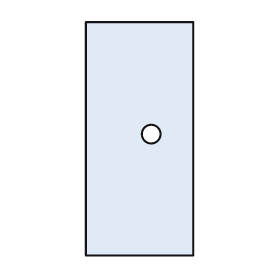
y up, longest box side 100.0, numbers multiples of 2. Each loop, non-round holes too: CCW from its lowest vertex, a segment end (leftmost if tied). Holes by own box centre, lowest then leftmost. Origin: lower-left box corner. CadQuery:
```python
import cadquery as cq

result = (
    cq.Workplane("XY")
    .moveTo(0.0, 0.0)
    .lineTo(46.0, 0.0)
    .lineTo(46.0, 100.0)
    .lineTo(0.0, 100.0)
    .close()
    .moveTo(28.0, 52.0)
    .circle(4.0)
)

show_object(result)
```